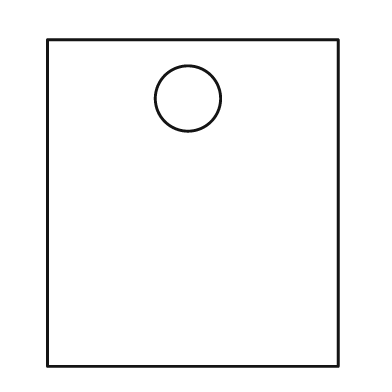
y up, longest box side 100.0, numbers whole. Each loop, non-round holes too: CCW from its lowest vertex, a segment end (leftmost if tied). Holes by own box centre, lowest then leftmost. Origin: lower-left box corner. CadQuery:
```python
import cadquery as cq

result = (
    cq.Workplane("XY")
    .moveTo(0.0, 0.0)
    .lineTo(89.0, 0.0)
    .lineTo(89.0, 100.0)
    .lineTo(0.0, 100.0)
    .close()
    .moveTo(43.0, 82.0)
    .circle(10.0)
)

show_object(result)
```